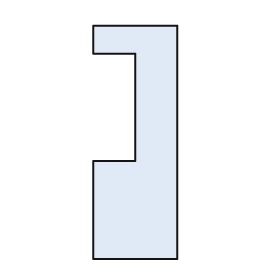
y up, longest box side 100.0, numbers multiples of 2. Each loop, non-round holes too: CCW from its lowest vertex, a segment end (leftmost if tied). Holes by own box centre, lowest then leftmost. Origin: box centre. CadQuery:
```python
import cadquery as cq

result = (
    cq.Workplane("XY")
    .moveTo(-18.0, -50.0)
    .lineTo(18.0, -50.0)
    .lineTo(18.0, 50.0)
    .lineTo(-18.0, 50.0)
    .lineTo(-18.0, 38.0)
    .lineTo(0.0, 38.0)
    .lineTo(0.0, -8.0)
    .lineTo(-18.0, -8.0)
    .close()
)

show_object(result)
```